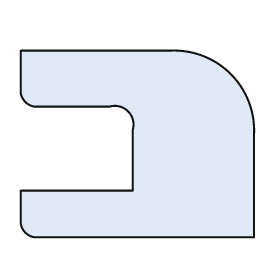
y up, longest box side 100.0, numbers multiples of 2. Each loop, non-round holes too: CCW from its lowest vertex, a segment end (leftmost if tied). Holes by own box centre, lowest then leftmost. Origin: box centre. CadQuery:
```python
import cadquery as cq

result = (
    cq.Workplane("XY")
    .moveTo(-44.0, -40.0)
    .lineTo(50.0, -40.0)
    .lineTo(50.0, 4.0)
    .threePointArc((40.0, 30.0), (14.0, 40.0))
    .lineTo(-50.0, 40.0)
    .lineTo(-50.0, 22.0)
    .threePointArc((-48.0, 18.0), (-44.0, 16.0))
    .lineTo(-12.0, 16.0)
    .threePointArc((-4.0, 14.0), (-2.0, 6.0))
    .lineTo(-2.0, -20.0)
    .lineTo(-50.0, -20.0)
    .lineTo(-50.0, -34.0)
    .threePointArc((-48.0, -38.0), (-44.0, -40.0))
    .close()
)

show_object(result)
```